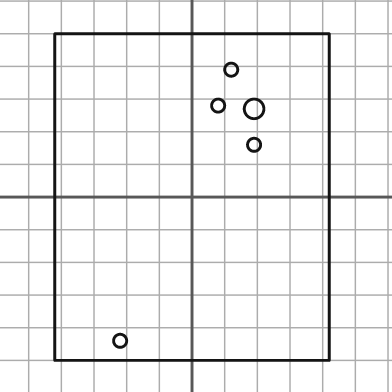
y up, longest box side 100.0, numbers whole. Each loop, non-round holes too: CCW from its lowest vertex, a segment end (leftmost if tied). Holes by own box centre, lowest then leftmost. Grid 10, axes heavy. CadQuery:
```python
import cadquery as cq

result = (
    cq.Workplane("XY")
    .moveTo(-42.0, -50.0)
    .lineTo(42.0, -50.0)
    .lineTo(42.0, 50.0)
    .lineTo(-42.0, 50.0)
    .close()
    .moveTo(-22.0, -44.0)
    .circle(2.0)
    .moveTo(19.0, 16.0)
    .circle(2.0)
    .moveTo(19.0, 27.0)
    .circle(3.0)
    .moveTo(8.0, 28.0)
    .circle(2.0)
    .moveTo(12.0, 39.0)
    .circle(2.0)
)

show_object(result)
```